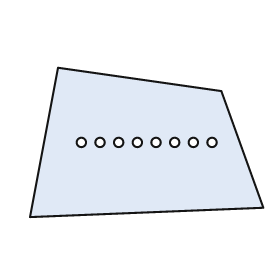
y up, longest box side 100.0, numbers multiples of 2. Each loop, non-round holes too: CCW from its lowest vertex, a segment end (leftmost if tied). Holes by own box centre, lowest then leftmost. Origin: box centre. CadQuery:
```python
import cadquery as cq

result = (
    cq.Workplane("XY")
    .moveTo(-50.0, -32.0)
    .lineTo(50.0, -28.0)
    .lineTo(32.0, 22.0)
    .lineTo(-38.0, 32.0)
    .close()
    .moveTo(-28.0, 0.0)
    .circle(2.0)
    .moveTo(-20.0, 0.0)
    .circle(2.0)
    .moveTo(-12.0, 0.0)
    .circle(2.0)
    .moveTo(-4.0, 0.0)
    .circle(2.0)
    .moveTo(4.0, 0.0)
    .circle(2.0)
    .moveTo(12.0, 0.0)
    .circle(2.0)
    .moveTo(20.0, 0.0)
    .circle(2.0)
    .moveTo(28.0, 0.0)
    .circle(2.0)
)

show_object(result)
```